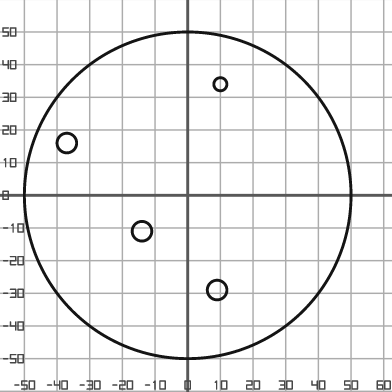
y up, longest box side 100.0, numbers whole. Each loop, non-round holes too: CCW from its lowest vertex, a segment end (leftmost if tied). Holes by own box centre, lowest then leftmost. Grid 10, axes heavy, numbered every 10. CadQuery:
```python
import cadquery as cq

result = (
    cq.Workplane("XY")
    .moveTo(0.0, 0.0)
    .circle(50.0)
    .moveTo(9.0, -29.0)
    .circle(3.0)
    .moveTo(-14.0, -11.0)
    .circle(3.0)
    .moveTo(-37.0, 16.0)
    .circle(3.0)
    .moveTo(10.0, 34.0)
    .circle(2.0)
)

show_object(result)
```